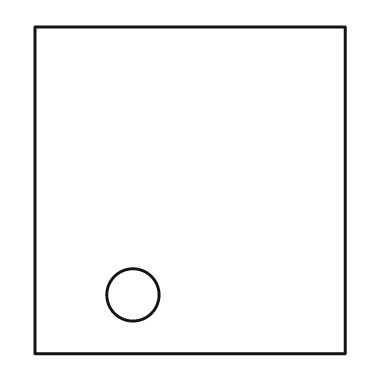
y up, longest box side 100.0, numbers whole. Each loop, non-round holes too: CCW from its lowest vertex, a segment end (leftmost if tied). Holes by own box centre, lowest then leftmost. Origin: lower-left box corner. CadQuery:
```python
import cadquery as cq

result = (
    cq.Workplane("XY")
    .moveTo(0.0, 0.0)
    .lineTo(95.0, 0.0)
    .lineTo(95.0, 100.0)
    .lineTo(0.0, 100.0)
    .close()
    .moveTo(30.0, 18.0)
    .circle(8.0)
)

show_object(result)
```